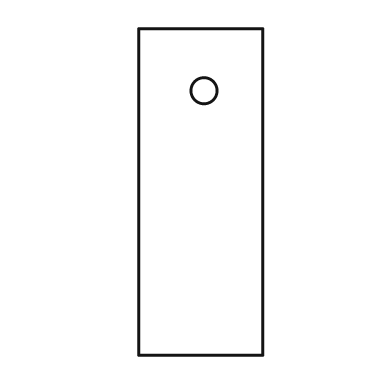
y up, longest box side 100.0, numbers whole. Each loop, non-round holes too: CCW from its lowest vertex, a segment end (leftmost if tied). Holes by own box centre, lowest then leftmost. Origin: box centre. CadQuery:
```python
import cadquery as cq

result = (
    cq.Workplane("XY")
    .moveTo(-19.0, -50.0)
    .lineTo(19.0, -50.0)
    .lineTo(19.0, 50.0)
    .lineTo(-19.0, 50.0)
    .close()
    .moveTo(1.0, 31.0)
    .circle(4.0)
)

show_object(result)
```